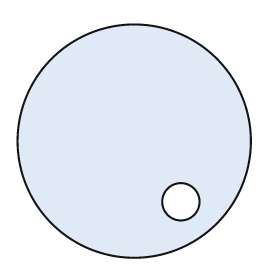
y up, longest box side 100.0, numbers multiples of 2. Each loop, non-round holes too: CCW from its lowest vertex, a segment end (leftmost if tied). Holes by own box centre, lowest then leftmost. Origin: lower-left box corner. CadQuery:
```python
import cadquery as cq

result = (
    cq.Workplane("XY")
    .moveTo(50.0, 50.0)
    .circle(50.0)
    .moveTo(70.0, 24.0)
    .circle(8.0)
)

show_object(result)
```